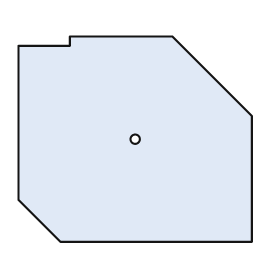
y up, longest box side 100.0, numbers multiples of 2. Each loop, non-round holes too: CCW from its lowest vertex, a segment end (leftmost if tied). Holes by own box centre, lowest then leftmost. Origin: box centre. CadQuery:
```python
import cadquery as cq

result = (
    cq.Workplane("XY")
    .moveTo(-32.0, -44.0)
    .lineTo(50.0, -44.0)
    .lineTo(50.0, 10.0)
    .lineTo(16.0, 44.0)
    .lineTo(-28.0, 44.0)
    .lineTo(-28.0, 40.0)
    .lineTo(-50.0, 40.0)
    .lineTo(-50.0, -26.0)
    .close()
    .moveTo(0.0, 0.0)
    .circle(2.0)
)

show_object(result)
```